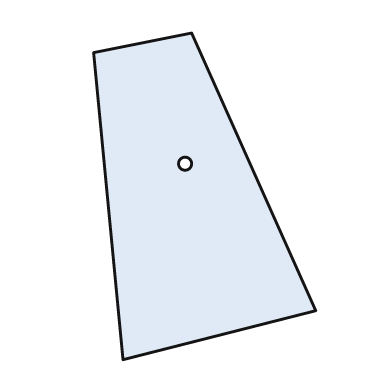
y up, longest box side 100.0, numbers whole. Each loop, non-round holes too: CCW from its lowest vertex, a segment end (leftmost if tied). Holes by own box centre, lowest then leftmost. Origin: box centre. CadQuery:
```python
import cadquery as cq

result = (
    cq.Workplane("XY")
    .moveTo(-25.0, -50.0)
    .lineTo(34.0, -35.0)
    .lineTo(-4.0, 50.0)
    .lineTo(-34.0, 44.0)
    .close()
    .moveTo(-6.0, 10.0)
    .circle(2.0)
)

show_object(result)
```